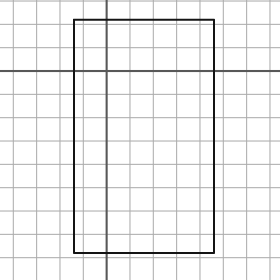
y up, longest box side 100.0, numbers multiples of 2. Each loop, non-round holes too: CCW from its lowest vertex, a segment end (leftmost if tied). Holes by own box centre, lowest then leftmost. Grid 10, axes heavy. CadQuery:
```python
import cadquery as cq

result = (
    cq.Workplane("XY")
    .moveTo(-14.0, -78.0)
    .lineTo(46.0, -78.0)
    .lineTo(46.0, 22.0)
    .lineTo(-14.0, 22.0)
    .close()
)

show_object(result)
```